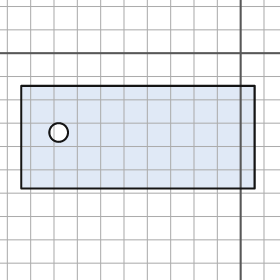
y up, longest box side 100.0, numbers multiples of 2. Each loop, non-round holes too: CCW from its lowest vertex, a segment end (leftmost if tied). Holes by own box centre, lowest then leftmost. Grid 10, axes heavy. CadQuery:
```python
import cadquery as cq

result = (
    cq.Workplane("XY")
    .moveTo(-94.0, -58.0)
    .lineTo(6.0, -58.0)
    .lineTo(6.0, -14.0)
    .lineTo(-94.0, -14.0)
    .close()
    .moveTo(-78.0, -34.0)
    .circle(4.0)
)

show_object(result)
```